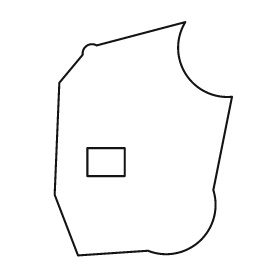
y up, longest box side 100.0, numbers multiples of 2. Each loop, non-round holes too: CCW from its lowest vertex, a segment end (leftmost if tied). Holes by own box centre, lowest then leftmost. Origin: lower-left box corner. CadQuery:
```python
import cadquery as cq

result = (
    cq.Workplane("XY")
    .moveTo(10.0, 0.0)
    .lineTo(40.0, 2.0)
    .threePointArc((62.0, 6.0), (68.0, 28.0))
    .lineTo(76.0, 68.0)
    .threePointArc((56.0, 78.0), (56.0, 100.0))
    .lineTo(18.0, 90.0)
    .threePointArc((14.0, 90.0), (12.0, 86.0))
    .lineTo(2.0, 74.0)
    .lineTo(0.0, 26.0)
    .close()
    .moveTo(14.0, 34.0)
    .lineTo(30.0, 34.0)
    .lineTo(30.0, 46.0)
    .lineTo(14.0, 46.0)
    .close()
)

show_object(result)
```